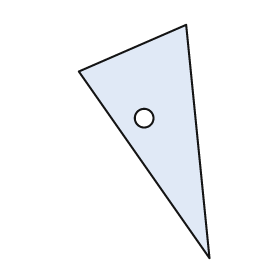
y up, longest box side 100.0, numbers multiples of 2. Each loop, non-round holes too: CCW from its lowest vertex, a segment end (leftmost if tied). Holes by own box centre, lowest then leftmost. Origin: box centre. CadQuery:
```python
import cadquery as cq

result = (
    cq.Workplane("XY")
    .moveTo(28.0, -50.0)
    .lineTo(18.0, 50.0)
    .lineTo(-28.0, 30.0)
    .close()
    .moveTo(0.0, 10.0)
    .circle(4.0)
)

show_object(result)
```